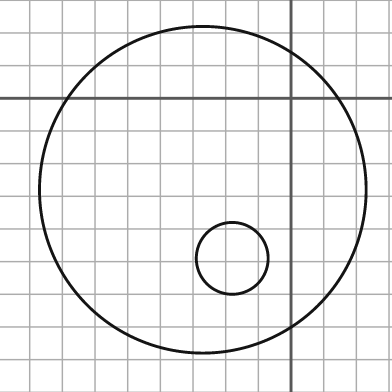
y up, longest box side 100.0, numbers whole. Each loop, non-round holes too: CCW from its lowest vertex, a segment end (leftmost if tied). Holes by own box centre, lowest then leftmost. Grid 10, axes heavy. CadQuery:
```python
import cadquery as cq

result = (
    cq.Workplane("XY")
    .moveTo(-27.0, -28.0)
    .circle(50.0)
    .moveTo(-18.0, -49.0)
    .circle(11.0)
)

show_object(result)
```